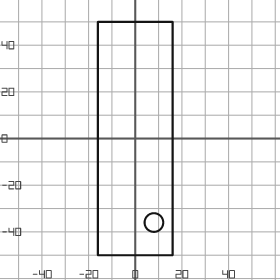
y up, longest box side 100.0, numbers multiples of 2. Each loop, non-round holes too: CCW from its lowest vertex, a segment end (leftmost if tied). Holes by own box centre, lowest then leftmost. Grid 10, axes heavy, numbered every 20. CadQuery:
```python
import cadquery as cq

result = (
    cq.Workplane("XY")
    .moveTo(-16.0, -50.0)
    .lineTo(16.0, -50.0)
    .lineTo(16.0, 50.0)
    .lineTo(-16.0, 50.0)
    .close()
    .moveTo(8.0, -36.0)
    .circle(4.0)
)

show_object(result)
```